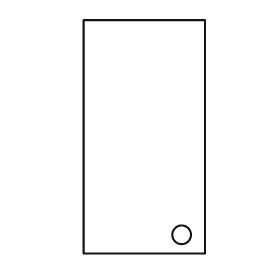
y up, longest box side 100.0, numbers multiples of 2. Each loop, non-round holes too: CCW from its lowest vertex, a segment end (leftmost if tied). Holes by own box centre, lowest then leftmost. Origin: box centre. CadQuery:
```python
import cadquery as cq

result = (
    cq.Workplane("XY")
    .moveTo(-26.0, -50.0)
    .lineTo(26.0, -50.0)
    .lineTo(26.0, 50.0)
    .lineTo(-26.0, 50.0)
    .close()
    .moveTo(16.0, -42.0)
    .circle(4.0)
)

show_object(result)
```